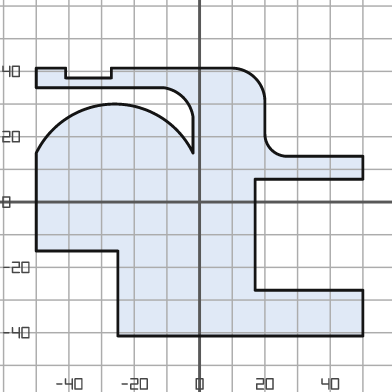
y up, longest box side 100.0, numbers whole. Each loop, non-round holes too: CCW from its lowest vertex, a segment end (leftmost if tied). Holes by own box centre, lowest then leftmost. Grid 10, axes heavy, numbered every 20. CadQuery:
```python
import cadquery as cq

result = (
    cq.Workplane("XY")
    .moveTo(-25.0, -41.0)
    .lineTo(50.0, -41.0)
    .lineTo(50.0, -27.0)
    .lineTo(17.0, -27.0)
    .lineTo(17.0, 7.0)
    .lineTo(50.0, 7.0)
    .lineTo(50.0, 14.0)
    .lineTo(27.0, 14.0)
    .threePointArc((22.0, 16.0), (20.0, 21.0))
    .lineTo(20.0, 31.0)
    .threePointArc((17.0, 38.0), (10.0, 41.0))
    .lineTo(-27.0, 41.0)
    .lineTo(-27.0, 38.0)
    .lineTo(-41.0, 38.0)
    .lineTo(-41.0, 41.0)
    .lineTo(-50.0, 41.0)
    .lineTo(-50.0, 35.0)
    .lineTo(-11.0, 35.0)
    .threePointArc((-5.0, 32.0), (-2.0, 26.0))
    .lineTo(-2.0, 15.0)
    .threePointArc((-26.0, 30.0), (-50.0, 15.0))
    .lineTo(-50.0, -15.0)
    .lineTo(-25.0, -15.0)
    .close()
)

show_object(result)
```